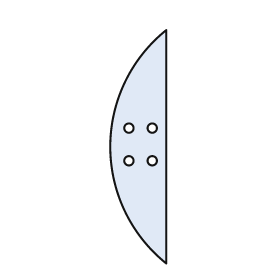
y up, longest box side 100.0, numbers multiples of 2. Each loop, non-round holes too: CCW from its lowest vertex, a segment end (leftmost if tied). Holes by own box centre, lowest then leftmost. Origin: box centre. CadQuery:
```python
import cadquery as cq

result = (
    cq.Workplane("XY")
    .moveTo(12.0, -50.0)
    .lineTo(12.0, 50.0)
    .threePointArc((-12.0, 0.0), (12.0, -50.0))
    .close()
    .moveTo(-4.0, -6.0)
    .circle(2.0)
    .moveTo(6.0, -6.0)
    .circle(2.0)
    .moveTo(-4.0, 8.0)
    .circle(2.0)
    .moveTo(6.0, 8.0)
    .circle(2.0)
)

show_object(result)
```